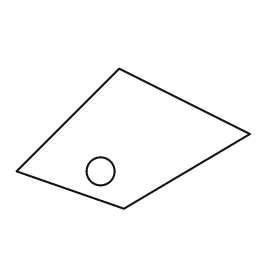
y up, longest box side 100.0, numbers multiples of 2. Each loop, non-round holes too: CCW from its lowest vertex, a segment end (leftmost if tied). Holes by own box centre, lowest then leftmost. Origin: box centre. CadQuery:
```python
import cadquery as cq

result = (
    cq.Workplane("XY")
    .moveTo(-4.0, -30.0)
    .lineTo(50.0, 2.0)
    .lineTo(-6.0, 30.0)
    .lineTo(-50.0, -14.0)
    .close()
    .moveTo(-14.0, -14.0)
    .circle(6.0)
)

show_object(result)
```